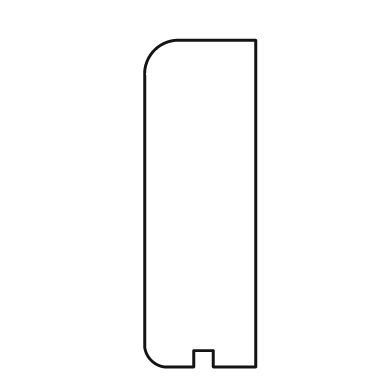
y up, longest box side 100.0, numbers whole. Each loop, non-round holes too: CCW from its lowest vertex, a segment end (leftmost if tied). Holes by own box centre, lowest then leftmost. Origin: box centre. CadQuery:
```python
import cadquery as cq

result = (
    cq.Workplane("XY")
    .moveTo(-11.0, -50.0)
    .lineTo(-2.0, -50.0)
    .lineTo(-2.0, -45.0)
    .lineTo(4.0, -45.0)
    .lineTo(4.0, -50.0)
    .lineTo(17.0, -50.0)
    .lineTo(17.0, 50.0)
    .lineTo(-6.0, 50.0)
    .threePointArc((-14.0, 47.0), (-17.0, 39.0))
    .lineTo(-17.0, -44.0)
    .threePointArc((-15.0, -48.0), (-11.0, -50.0))
    .close()
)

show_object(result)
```